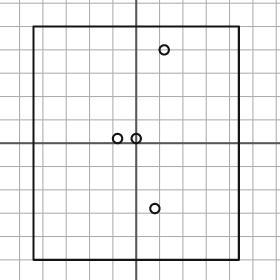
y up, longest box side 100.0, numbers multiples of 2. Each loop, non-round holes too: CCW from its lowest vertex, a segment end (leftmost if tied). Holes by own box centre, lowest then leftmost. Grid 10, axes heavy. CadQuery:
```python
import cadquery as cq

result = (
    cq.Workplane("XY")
    .moveTo(-44.0, -50.0)
    .lineTo(44.0, -50.0)
    .lineTo(44.0, 50.0)
    .lineTo(-44.0, 50.0)
    .close()
    .moveTo(8.0, -28.0)
    .circle(2.0)
    .moveTo(-8.0, 2.0)
    .circle(2.0)
    .moveTo(0.0, 2.0)
    .circle(2.0)
    .moveTo(12.0, 40.0)
    .circle(2.0)
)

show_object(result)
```